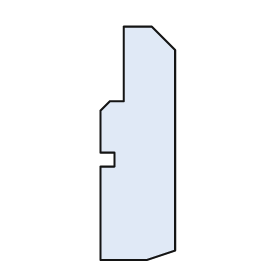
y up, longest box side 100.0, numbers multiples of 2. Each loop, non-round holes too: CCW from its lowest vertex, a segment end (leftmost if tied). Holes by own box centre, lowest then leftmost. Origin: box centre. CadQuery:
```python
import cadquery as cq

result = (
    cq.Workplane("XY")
    .moveTo(-16.0, -50.0)
    .lineTo(4.0, -50.0)
    .lineTo(16.0, -46.0)
    .lineTo(16.0, 40.0)
    .lineTo(6.0, 50.0)
    .lineTo(-6.0, 50.0)
    .lineTo(-6.0, 18.0)
    .lineTo(-12.0, 18.0)
    .lineTo(-16.0, 14.0)
    .lineTo(-16.0, -4.0)
    .lineTo(-10.0, -4.0)
    .lineTo(-10.0, -10.0)
    .lineTo(-16.0, -10.0)
    .close()
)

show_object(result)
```